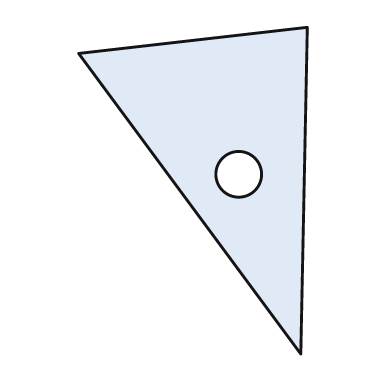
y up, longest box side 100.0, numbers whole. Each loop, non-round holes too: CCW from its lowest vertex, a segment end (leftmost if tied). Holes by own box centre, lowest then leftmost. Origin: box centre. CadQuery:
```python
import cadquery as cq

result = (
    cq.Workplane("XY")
    .moveTo(33.0, -50.0)
    .lineTo(35.0, 50.0)
    .lineTo(-35.0, 42.0)
    .close()
    .moveTo(14.0, 5.0)
    .circle(7.0)
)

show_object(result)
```